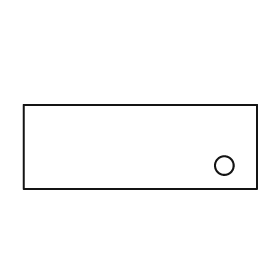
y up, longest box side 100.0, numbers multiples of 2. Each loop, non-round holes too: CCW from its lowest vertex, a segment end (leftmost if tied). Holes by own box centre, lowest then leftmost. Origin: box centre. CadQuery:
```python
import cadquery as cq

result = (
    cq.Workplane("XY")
    .moveTo(-50.0, -18.0)
    .lineTo(50.0, -18.0)
    .lineTo(50.0, 18.0)
    .lineTo(-50.0, 18.0)
    .close()
    .moveTo(36.0, -8.0)
    .circle(4.0)
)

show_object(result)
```